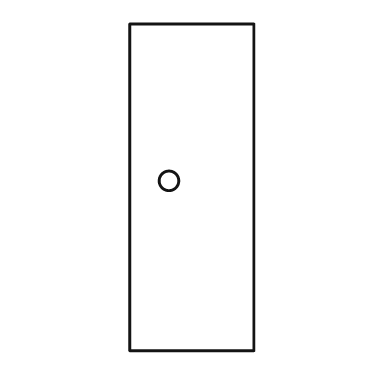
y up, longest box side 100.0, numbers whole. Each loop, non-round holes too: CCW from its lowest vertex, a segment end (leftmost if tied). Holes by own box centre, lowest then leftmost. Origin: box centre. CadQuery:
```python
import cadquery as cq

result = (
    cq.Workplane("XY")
    .moveTo(-19.0, -50.0)
    .lineTo(19.0, -50.0)
    .lineTo(19.0, 50.0)
    .lineTo(-19.0, 50.0)
    .close()
    .moveTo(-7.0, 2.0)
    .circle(3.0)
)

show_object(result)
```